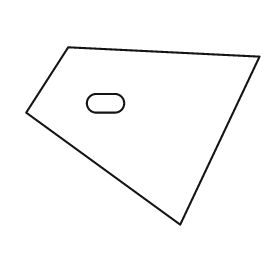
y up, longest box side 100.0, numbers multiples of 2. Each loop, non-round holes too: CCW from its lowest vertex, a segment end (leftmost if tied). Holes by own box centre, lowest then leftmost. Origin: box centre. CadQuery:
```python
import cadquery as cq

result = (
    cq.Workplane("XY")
    .moveTo(16.0, -38.0)
    .lineTo(50.0, 34.0)
    .lineTo(-32.0, 38.0)
    .lineTo(-50.0, 10.0)
    .close()
    .moveTo(-20.0, 10.0)
    .lineTo(-12.0, 10.0)
    .threePointArc((-8.0, 14.0), (-12.0, 18.0))
    .lineTo(-20.0, 18.0)
    .threePointArc((-24.0, 14.0), (-20.0, 10.0))
    .close()
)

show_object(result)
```